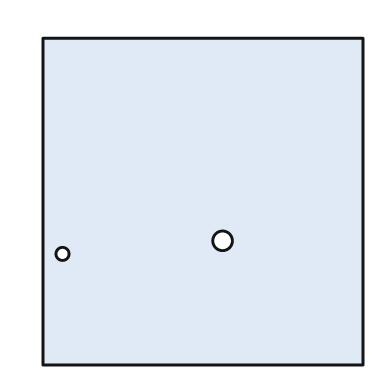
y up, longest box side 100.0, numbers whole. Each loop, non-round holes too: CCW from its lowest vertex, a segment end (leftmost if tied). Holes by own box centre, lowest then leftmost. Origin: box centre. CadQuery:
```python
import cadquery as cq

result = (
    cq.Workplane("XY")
    .moveTo(-49.0, -50.0)
    .lineTo(49.0, -50.0)
    .lineTo(49.0, 50.0)
    .lineTo(-49.0, 50.0)
    .close()
    .moveTo(-43.0, -16.0)
    .circle(2.0)
    .moveTo(6.0, -12.0)
    .circle(3.0)
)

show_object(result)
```